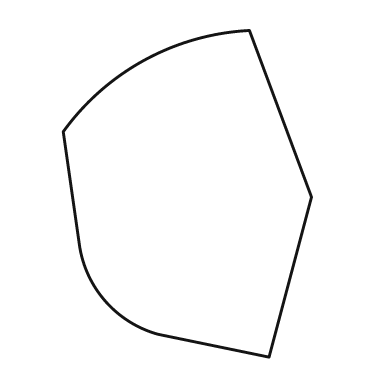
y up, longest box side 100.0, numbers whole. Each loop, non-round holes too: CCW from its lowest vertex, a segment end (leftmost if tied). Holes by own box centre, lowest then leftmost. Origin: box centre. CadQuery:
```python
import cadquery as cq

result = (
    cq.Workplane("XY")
    .moveTo(25.0, -50.0)
    .lineTo(38.0, -1.0)
    .lineTo(19.0, 50.0)
    .threePointArc((-13.0, 41.0), (-38.0, 19.0))
    .lineTo(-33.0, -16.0)
    .threePointArc((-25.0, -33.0), (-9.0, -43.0))
    .close()
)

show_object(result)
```